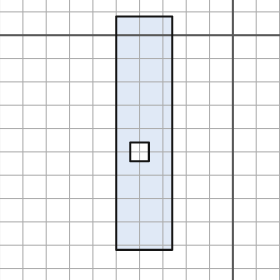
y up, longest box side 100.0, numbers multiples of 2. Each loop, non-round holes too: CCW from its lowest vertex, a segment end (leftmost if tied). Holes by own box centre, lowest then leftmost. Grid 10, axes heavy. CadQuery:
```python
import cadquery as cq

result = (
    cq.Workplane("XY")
    .moveTo(-50.0, -92.0)
    .lineTo(-26.0, -92.0)
    .lineTo(-26.0, 8.0)
    .lineTo(-50.0, 8.0)
    .close()
    .moveTo(-44.0, -54.0)
    .lineTo(-36.0, -54.0)
    .lineTo(-36.0, -46.0)
    .lineTo(-44.0, -46.0)
    .close()
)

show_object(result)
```